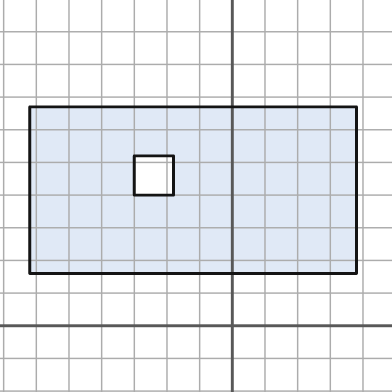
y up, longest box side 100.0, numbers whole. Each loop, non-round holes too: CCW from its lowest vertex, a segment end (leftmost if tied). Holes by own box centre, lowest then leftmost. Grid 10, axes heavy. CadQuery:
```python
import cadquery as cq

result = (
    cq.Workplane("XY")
    .moveTo(-62.0, 16.0)
    .lineTo(38.0, 16.0)
    .lineTo(38.0, 67.0)
    .lineTo(-62.0, 67.0)
    .close()
    .moveTo(-30.0, 40.0)
    .lineTo(-18.0, 40.0)
    .lineTo(-18.0, 52.0)
    .lineTo(-30.0, 52.0)
    .close()
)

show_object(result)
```